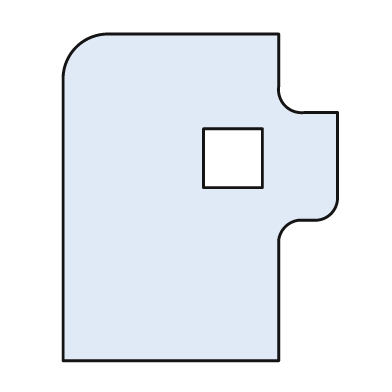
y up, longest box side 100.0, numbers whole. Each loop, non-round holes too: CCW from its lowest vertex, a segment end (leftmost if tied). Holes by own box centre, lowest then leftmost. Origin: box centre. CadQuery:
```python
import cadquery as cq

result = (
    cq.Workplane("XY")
    .moveTo(-42.0, -50.0)
    .lineTo(24.0, -50.0)
    .lineTo(24.0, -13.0)
    .threePointArc((26.0, -9.0), (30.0, -7.0))
    .lineTo(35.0, -7.0)
    .threePointArc((40.0, -5.0), (42.0, 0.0))
    .lineTo(42.0, 26.0)
    .lineTo(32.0, 26.0)
    .threePointArc((26.0, 28.0), (24.0, 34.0))
    .lineTo(24.0, 50.0)
    .lineTo(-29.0, 50.0)
    .threePointArc((-38.0, 46.0), (-42.0, 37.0))
    .close()
    .moveTo(1.0, 3.0)
    .lineTo(19.0, 3.0)
    .lineTo(19.0, 21.0)
    .lineTo(1.0, 21.0)
    .close()
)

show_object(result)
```